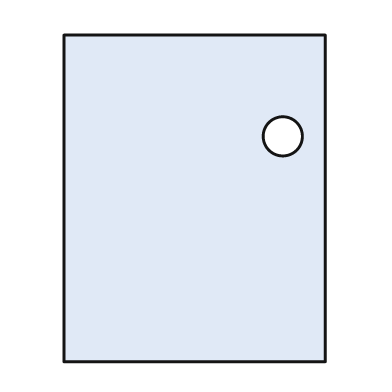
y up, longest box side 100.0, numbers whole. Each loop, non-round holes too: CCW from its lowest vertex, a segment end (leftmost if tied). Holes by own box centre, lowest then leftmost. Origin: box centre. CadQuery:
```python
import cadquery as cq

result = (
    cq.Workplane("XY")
    .moveTo(-40.0, -50.0)
    .lineTo(40.0, -50.0)
    .lineTo(40.0, 50.0)
    .lineTo(-40.0, 50.0)
    .close()
    .moveTo(27.0, 19.0)
    .circle(6.0)
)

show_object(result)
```